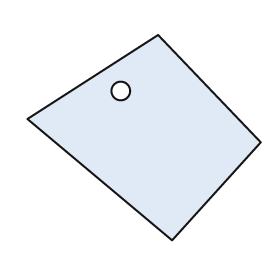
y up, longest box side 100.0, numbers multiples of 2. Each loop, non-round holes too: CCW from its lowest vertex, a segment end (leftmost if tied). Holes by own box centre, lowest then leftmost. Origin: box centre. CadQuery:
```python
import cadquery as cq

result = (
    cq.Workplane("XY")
    .moveTo(12.0, -44.0)
    .lineTo(50.0, -2.0)
    .lineTo(6.0, 44.0)
    .lineTo(-50.0, 8.0)
    .close()
    .moveTo(-10.0, 20.0)
    .circle(4.0)
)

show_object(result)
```